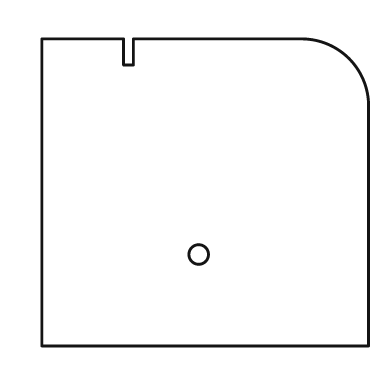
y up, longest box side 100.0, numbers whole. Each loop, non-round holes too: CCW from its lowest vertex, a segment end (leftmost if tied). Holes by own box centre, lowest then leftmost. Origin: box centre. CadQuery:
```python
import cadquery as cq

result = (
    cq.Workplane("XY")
    .moveTo(-50.0, -47.0)
    .lineTo(50.0, -47.0)
    .lineTo(50.0, 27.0)
    .threePointArc((44.0, 41.0), (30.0, 47.0))
    .lineTo(-22.0, 47.0)
    .lineTo(-22.0, 39.0)
    .lineTo(-25.0, 39.0)
    .lineTo(-25.0, 47.0)
    .lineTo(-50.0, 47.0)
    .close()
    .moveTo(-2.0, -19.0)
    .circle(3.0)
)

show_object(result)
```